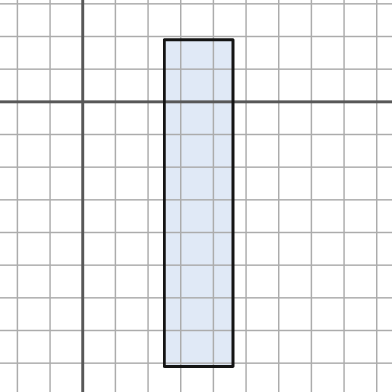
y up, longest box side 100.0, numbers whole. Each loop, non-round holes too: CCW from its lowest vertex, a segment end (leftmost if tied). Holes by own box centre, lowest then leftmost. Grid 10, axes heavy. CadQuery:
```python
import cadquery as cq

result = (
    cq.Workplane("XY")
    .moveTo(25.0, -81.0)
    .lineTo(46.0, -81.0)
    .lineTo(46.0, 19.0)
    .lineTo(25.0, 19.0)
    .close()
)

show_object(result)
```